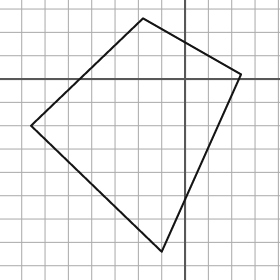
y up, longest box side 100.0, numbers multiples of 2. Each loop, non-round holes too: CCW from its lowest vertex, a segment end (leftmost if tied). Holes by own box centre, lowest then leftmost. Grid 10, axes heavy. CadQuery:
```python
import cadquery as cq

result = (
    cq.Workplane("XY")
    .moveTo(-10.0, -74.0)
    .lineTo(24.0, 2.0)
    .lineTo(-18.0, 26.0)
    .lineTo(-66.0, -20.0)
    .close()
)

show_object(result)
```